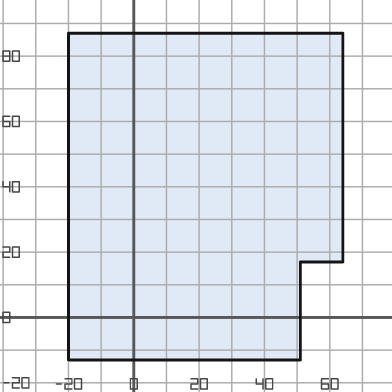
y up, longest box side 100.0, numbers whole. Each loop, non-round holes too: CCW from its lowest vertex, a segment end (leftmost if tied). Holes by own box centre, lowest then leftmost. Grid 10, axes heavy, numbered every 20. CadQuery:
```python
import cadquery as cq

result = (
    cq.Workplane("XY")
    .moveTo(-20.0, -13.0)
    .lineTo(51.0, -13.0)
    .lineTo(51.0, 17.0)
    .lineTo(64.0, 17.0)
    .lineTo(64.0, 87.0)
    .lineTo(-20.0, 87.0)
    .close()
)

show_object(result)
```